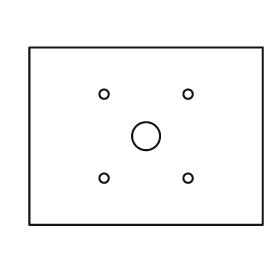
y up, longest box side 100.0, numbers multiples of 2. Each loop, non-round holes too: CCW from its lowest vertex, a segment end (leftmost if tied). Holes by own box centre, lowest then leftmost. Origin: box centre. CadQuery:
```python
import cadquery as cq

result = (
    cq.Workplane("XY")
    .moveTo(-50.0, -38.0)
    .lineTo(50.0, -38.0)
    .lineTo(50.0, 38.0)
    .lineTo(-50.0, 38.0)
    .close()
    .moveTo(-18.0, -18.0)
    .circle(2.0)
    .moveTo(18.0, -18.0)
    .circle(2.0)
    .moveTo(0.0, 0.0)
    .circle(6.0)
    .moveTo(-18.0, 18.0)
    .circle(2.0)
    .moveTo(18.0, 18.0)
    .circle(2.0)
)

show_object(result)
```